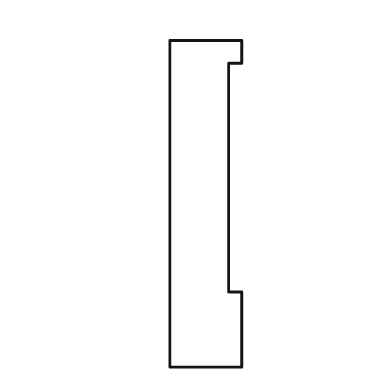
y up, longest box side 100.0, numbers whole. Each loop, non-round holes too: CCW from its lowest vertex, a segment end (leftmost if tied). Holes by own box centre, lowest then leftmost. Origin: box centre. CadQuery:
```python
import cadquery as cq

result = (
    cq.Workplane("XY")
    .moveTo(-11.0, -50.0)
    .lineTo(11.0, -50.0)
    .lineTo(11.0, -27.0)
    .lineTo(7.0, -27.0)
    .lineTo(7.0, 43.0)
    .lineTo(11.0, 43.0)
    .lineTo(11.0, 50.0)
    .lineTo(-11.0, 50.0)
    .close()
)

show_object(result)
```